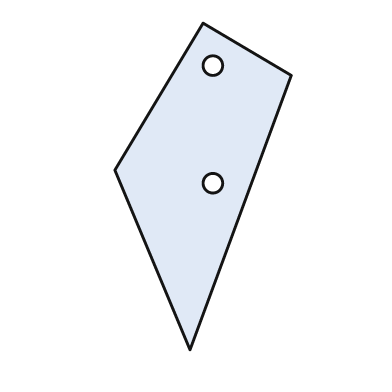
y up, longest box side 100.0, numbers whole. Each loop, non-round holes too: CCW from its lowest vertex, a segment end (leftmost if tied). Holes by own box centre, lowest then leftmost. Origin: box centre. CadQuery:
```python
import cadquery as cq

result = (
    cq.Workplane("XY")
    .moveTo(-4.0, -50.0)
    .lineTo(27.0, 34.0)
    .lineTo(0.0, 50.0)
    .lineTo(-27.0, 5.0)
    .close()
    .moveTo(3.0, 1.0)
    .circle(3.0)
    .moveTo(3.0, 37.0)
    .circle(3.0)
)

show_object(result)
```